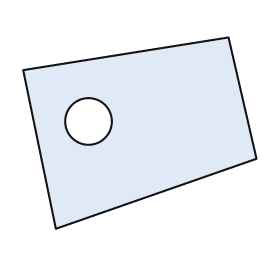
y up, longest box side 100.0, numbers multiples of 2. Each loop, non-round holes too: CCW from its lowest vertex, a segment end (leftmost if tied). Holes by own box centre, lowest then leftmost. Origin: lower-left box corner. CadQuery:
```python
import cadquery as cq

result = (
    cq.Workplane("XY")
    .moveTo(14.0, 0.0)
    .lineTo(100.0, 30.0)
    .lineTo(88.0, 82.0)
    .lineTo(0.0, 68.0)
    .close()
    .moveTo(28.0, 46.0)
    .circle(10.0)
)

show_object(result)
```